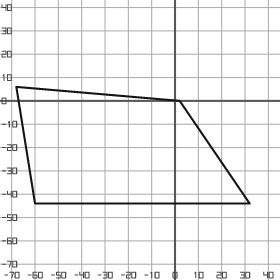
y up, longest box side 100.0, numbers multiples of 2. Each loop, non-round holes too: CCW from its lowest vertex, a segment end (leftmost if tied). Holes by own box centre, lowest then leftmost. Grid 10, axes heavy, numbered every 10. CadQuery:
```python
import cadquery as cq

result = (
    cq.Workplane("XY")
    .moveTo(-60.0, -44.0)
    .lineTo(32.0, -44.0)
    .lineTo(2.0, 0.0)
    .lineTo(-68.0, 6.0)
    .close()
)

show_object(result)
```